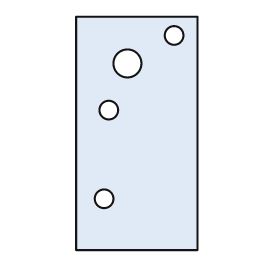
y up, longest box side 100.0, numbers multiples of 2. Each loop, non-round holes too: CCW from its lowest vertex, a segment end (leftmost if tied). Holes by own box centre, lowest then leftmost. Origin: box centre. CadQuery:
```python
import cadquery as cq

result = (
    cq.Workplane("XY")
    .moveTo(-26.0, -50.0)
    .lineTo(26.0, -50.0)
    .lineTo(26.0, 50.0)
    .lineTo(-26.0, 50.0)
    .close()
    .moveTo(-14.0, -28.0)
    .circle(4.0)
    .moveTo(-12.0, 10.0)
    .circle(4.0)
    .moveTo(-4.0, 30.0)
    .circle(6.0)
    .moveTo(16.0, 42.0)
    .circle(4.0)
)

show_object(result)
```